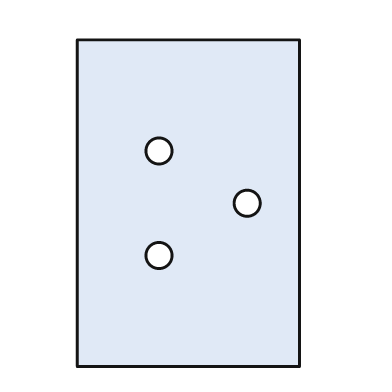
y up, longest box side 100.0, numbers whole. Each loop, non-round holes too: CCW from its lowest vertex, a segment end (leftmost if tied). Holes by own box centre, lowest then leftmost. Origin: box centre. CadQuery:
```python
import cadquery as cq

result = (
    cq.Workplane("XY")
    .moveTo(-34.0, -50.0)
    .lineTo(34.0, -50.0)
    .lineTo(34.0, 50.0)
    .lineTo(-34.0, 50.0)
    .close()
    .moveTo(-9.0, -16.0)
    .circle(4.0)
    .moveTo(18.0, 0.0)
    .circle(4.0)
    .moveTo(-9.0, 16.0)
    .circle(4.0)
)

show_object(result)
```